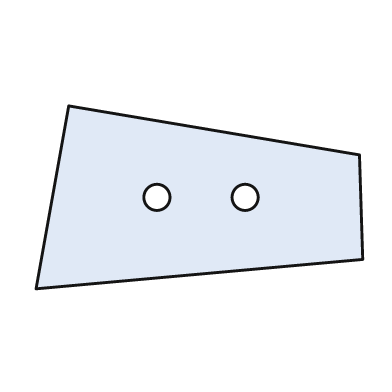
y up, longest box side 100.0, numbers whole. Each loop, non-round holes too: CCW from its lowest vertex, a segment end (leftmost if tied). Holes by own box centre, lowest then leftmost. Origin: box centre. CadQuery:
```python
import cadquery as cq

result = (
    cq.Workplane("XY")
    .moveTo(-50.0, -28.0)
    .lineTo(50.0, -19.0)
    .lineTo(49.0, 13.0)
    .lineTo(-40.0, 28.0)
    .close()
    .moveTo(-13.0, 0.0)
    .circle(4.0)
    .moveTo(14.0, 0.0)
    .circle(4.0)
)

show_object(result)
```